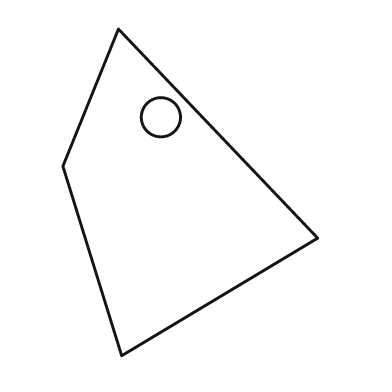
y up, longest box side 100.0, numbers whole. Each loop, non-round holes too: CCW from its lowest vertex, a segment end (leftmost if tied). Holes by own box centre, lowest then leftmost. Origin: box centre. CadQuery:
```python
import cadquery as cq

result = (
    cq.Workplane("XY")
    .moveTo(-21.0, -50.0)
    .lineTo(39.0, -14.0)
    .lineTo(-22.0, 50.0)
    .lineTo(-39.0, 8.0)
    .close()
    .moveTo(-9.0, 23.0)
    .circle(6.0)
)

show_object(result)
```